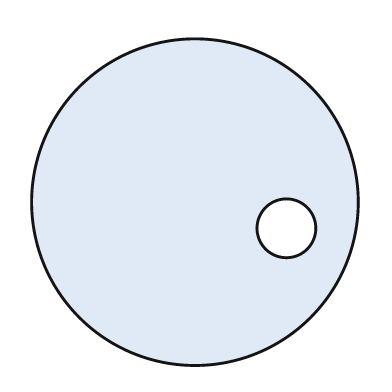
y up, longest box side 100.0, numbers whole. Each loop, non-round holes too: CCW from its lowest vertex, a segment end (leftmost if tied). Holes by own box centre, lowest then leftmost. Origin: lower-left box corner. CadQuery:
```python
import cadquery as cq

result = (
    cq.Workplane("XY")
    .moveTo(50.0, 50.0)
    .circle(50.0)
    .moveTo(78.0, 42.0)
    .circle(9.0)
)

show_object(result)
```